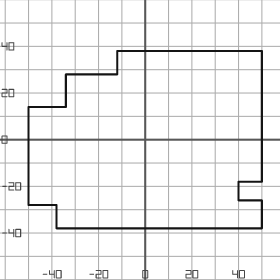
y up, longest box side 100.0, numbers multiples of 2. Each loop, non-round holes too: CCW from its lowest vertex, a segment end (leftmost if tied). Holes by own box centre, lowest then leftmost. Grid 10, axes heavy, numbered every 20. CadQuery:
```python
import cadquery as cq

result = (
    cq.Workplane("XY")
    .moveTo(-38.0, -38.0)
    .lineTo(50.0, -38.0)
    .lineTo(50.0, -26.0)
    .lineTo(40.0, -26.0)
    .lineTo(40.0, -18.0)
    .lineTo(50.0, -18.0)
    .lineTo(50.0, 38.0)
    .lineTo(-12.0, 38.0)
    .lineTo(-12.0, 28.0)
    .lineTo(-34.0, 28.0)
    .lineTo(-34.0, 14.0)
    .lineTo(-50.0, 14.0)
    .lineTo(-50.0, -28.0)
    .lineTo(-38.0, -28.0)
    .close()
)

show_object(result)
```